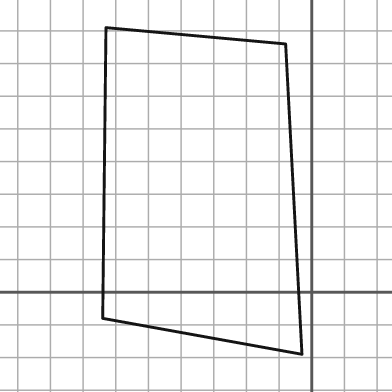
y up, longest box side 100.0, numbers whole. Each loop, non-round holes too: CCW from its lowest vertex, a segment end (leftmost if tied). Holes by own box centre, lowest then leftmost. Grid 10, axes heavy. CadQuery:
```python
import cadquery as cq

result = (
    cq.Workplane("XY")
    .moveTo(-3.0, -19.0)
    .lineTo(-8.0, 76.0)
    .lineTo(-63.0, 81.0)
    .lineTo(-64.0, -8.0)
    .close()
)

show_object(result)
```